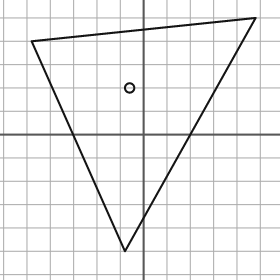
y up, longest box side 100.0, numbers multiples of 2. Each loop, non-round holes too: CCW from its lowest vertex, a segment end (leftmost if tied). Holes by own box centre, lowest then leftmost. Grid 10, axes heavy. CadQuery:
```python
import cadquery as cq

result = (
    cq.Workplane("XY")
    .moveTo(-8.0, -50.0)
    .lineTo(48.0, 50.0)
    .lineTo(-48.0, 40.0)
    .close()
    .moveTo(-6.0, 20.0)
    .circle(2.0)
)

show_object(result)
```